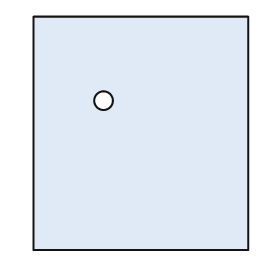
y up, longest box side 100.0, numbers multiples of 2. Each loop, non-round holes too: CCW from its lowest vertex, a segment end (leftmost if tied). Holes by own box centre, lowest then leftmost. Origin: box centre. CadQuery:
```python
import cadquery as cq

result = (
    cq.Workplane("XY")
    .moveTo(-46.0, -50.0)
    .lineTo(46.0, -50.0)
    .lineTo(46.0, 50.0)
    .lineTo(-46.0, 50.0)
    .close()
    .moveTo(-16.0, 14.0)
    .circle(4.0)
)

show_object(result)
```